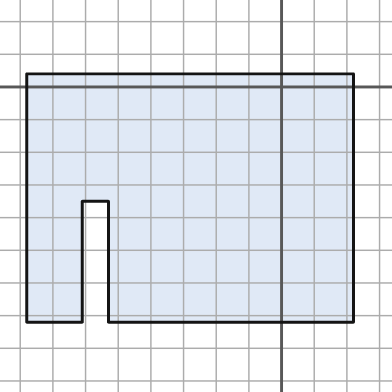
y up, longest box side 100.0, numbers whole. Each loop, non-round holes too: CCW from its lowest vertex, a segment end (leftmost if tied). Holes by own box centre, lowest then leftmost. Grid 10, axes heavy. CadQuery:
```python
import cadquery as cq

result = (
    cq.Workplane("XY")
    .moveTo(-78.0, -72.0)
    .lineTo(-61.0, -72.0)
    .lineTo(-61.0, -35.0)
    .lineTo(-53.0, -35.0)
    .lineTo(-53.0, -72.0)
    .lineTo(22.0, -72.0)
    .lineTo(22.0, 4.0)
    .lineTo(-78.0, 4.0)
    .close()
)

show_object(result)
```